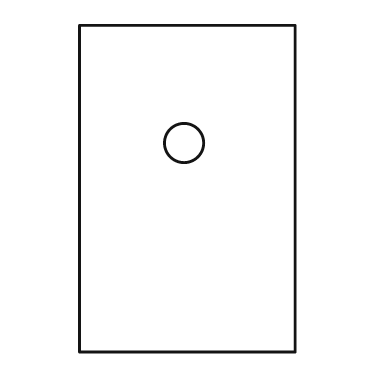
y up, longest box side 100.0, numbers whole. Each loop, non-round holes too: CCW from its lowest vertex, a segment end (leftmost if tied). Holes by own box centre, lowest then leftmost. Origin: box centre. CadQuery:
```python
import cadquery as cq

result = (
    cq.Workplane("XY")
    .moveTo(-33.0, -50.0)
    .lineTo(33.0, -50.0)
    .lineTo(33.0, 50.0)
    .lineTo(-33.0, 50.0)
    .close()
    .moveTo(-1.0, 14.0)
    .circle(6.0)
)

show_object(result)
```